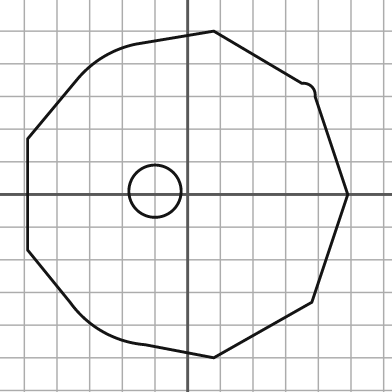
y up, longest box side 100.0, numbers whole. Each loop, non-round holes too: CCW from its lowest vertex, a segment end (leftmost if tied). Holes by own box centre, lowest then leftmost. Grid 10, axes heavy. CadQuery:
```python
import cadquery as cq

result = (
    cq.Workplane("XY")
    .moveTo(8.0, -50.0)
    .lineTo(38.0, -33.0)
    .lineTo(49.0, 0.0)
    .lineTo(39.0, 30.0)
    .threePointArc((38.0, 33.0), (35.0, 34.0))
    .lineTo(8.0, 50.0)
    .lineTo(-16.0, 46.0)
    .threePointArc((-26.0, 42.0), (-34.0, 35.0))
    .lineTo(-49.0, 17.0)
    .lineTo(-49.0, -17.0)
    .lineTo(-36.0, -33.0)
    .threePointArc((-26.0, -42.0), (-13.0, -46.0))
    .close()
    .moveTo(-10.0, 1.0)
    .circle(8.0)
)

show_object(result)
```